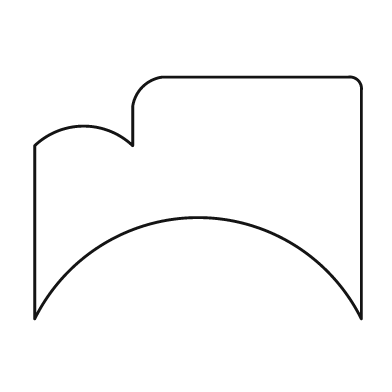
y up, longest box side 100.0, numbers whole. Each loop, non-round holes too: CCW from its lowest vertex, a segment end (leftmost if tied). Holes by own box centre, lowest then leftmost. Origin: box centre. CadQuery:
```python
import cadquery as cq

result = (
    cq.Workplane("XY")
    .moveTo(-50.0, -37.0)
    .threePointArc((0.0, -6.0), (50.0, -37.0))
    .lineTo(50.0, 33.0)
    .threePointArc((49.0, 36.0), (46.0, 37.0))
    .lineTo(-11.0, 37.0)
    .threePointArc((-17.0, 34.0), (-20.0, 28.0))
    .lineTo(-20.0, 16.0)
    .threePointArc((-35.0, 22.0), (-50.0, 16.0))
    .close()
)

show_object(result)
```